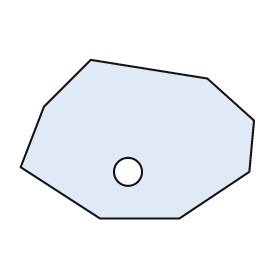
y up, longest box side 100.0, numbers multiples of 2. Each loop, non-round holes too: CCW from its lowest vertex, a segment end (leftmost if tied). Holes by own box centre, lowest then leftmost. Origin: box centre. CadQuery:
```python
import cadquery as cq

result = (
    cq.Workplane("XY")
    .moveTo(-16.0, -34.0)
    .lineTo(18.0, -34.0)
    .lineTo(48.0, -14.0)
    .lineTo(50.0, 8.0)
    .lineTo(30.0, 26.0)
    .lineTo(-20.0, 34.0)
    .lineTo(-40.0, 14.0)
    .lineTo(-50.0, -12.0)
    .close()
    .moveTo(-4.0, -14.0)
    .circle(6.0)
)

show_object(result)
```